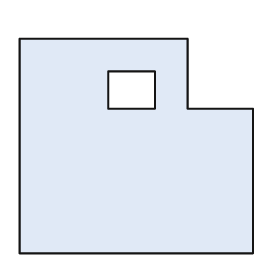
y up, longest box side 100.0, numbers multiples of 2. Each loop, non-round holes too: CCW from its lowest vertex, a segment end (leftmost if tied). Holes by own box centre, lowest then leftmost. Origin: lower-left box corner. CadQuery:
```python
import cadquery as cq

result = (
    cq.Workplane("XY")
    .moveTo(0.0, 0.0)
    .lineTo(100.0, 0.0)
    .lineTo(100.0, 62.0)
    .lineTo(72.0, 62.0)
    .lineTo(72.0, 92.0)
    .lineTo(0.0, 92.0)
    .close()
    .moveTo(38.0, 62.0)
    .lineTo(58.0, 62.0)
    .lineTo(58.0, 78.0)
    .lineTo(38.0, 78.0)
    .close()
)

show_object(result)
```